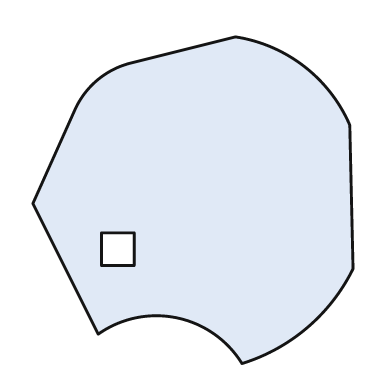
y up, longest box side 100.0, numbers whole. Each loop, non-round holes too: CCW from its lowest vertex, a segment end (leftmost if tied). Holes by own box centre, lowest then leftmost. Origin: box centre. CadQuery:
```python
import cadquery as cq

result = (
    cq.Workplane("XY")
    .moveTo(15.0, -50.0)
    .threePointArc((35.0, -39.0), (49.0, -21.0))
    .lineTo(48.0, 23.0)
    .threePointArc((34.0, 41.0), (13.0, 50.0))
    .lineTo(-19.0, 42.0)
    .threePointArc((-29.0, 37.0), (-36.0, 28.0))
    .lineTo(-49.0, -1.0)
    .lineTo(-29.0, -41.0)
    .threePointArc((-5.0, -36.0), (15.0, -50.0))
    .close()
    .moveTo(-28.0, -20.0)
    .lineTo(-18.0, -20.0)
    .lineTo(-18.0, -10.0)
    .lineTo(-28.0, -10.0)
    .close()
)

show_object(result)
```